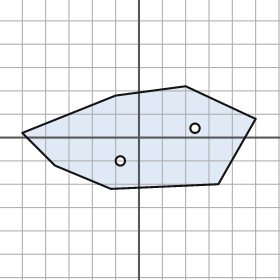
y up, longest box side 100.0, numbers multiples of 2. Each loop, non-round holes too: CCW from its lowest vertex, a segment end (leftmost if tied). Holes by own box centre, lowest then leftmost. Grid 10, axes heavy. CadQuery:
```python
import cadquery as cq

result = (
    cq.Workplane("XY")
    .moveTo(-12.0, -22.0)
    .lineTo(34.0, -20.0)
    .lineTo(50.0, 8.0)
    .lineTo(20.0, 22.0)
    .lineTo(-10.0, 18.0)
    .lineTo(-50.0, 2.0)
    .lineTo(-36.0, -12.0)
    .close()
    .moveTo(-8.0, -10.0)
    .circle(2.0)
    .moveTo(24.0, 4.0)
    .circle(2.0)
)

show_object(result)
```